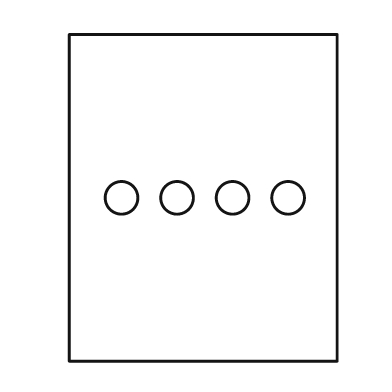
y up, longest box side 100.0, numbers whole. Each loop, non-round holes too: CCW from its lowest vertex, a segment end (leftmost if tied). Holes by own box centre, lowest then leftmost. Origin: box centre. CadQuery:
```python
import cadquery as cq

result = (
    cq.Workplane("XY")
    .moveTo(-41.0, -50.0)
    .lineTo(41.0, -50.0)
    .lineTo(41.0, 50.0)
    .lineTo(-41.0, 50.0)
    .close()
    .moveTo(-25.0, 0.0)
    .circle(5.0)
    .moveTo(-8.0, 0.0)
    .circle(5.0)
    .moveTo(9.0, 0.0)
    .circle(5.0)
    .moveTo(26.0, 0.0)
    .circle(5.0)
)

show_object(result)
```